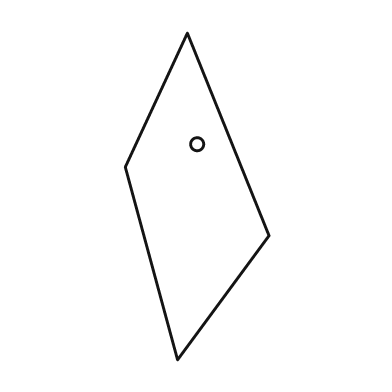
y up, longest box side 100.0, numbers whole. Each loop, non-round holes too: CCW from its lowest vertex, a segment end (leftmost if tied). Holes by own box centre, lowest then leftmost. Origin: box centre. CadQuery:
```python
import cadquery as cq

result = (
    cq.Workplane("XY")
    .moveTo(-6.0, -50.0)
    .lineTo(22.0, -12.0)
    .lineTo(-3.0, 50.0)
    .lineTo(-22.0, 9.0)
    .close()
    .moveTo(0.0, 16.0)
    .circle(2.0)
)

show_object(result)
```